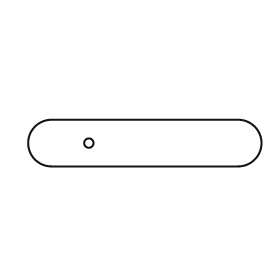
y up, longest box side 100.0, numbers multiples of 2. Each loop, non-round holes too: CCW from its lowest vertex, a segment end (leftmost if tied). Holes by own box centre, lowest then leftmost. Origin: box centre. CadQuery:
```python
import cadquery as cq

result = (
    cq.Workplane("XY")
    .moveTo(-40.0, -10.0)
    .lineTo(40.0, -10.0)
    .threePointArc((50.0, 0.0), (40.0, 10.0))
    .lineTo(-40.0, 10.0)
    .threePointArc((-50.0, 0.0), (-40.0, -10.0))
    .close()
    .moveTo(-24.0, 0.0)
    .circle(2.0)
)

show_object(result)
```